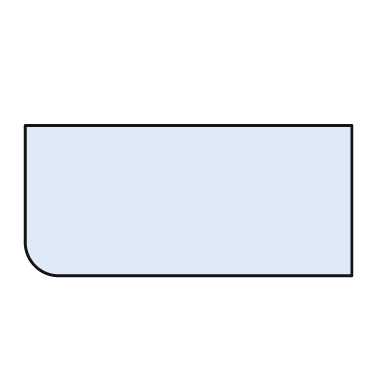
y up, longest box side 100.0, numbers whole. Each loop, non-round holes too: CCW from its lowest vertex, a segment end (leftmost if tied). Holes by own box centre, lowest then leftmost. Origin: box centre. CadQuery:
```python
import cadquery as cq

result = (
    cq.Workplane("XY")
    .moveTo(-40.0, -23.0)
    .lineTo(50.0, -23.0)
    .lineTo(50.0, 23.0)
    .lineTo(-50.0, 23.0)
    .lineTo(-50.0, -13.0)
    .threePointArc((-47.0, -20.0), (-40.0, -23.0))
    .close()
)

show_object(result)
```